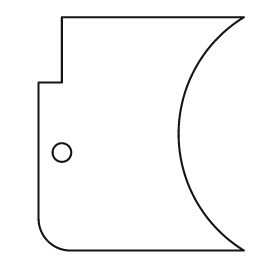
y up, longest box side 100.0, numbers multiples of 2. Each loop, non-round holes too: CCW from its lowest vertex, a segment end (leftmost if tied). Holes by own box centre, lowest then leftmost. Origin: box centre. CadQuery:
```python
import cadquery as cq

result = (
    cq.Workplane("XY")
    .moveTo(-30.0, -50.0)
    .lineTo(44.0, -50.0)
    .threePointArc((16.0, 0.0), (44.0, 50.0))
    .lineTo(-34.0, 50.0)
    .lineTo(-34.0, 22.0)
    .lineTo(-44.0, 22.0)
    .lineTo(-44.0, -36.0)
    .threePointArc((-40.0, -46.0), (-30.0, -50.0))
    .close()
    .moveTo(-34.0, -8.0)
    .circle(4.0)
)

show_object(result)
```